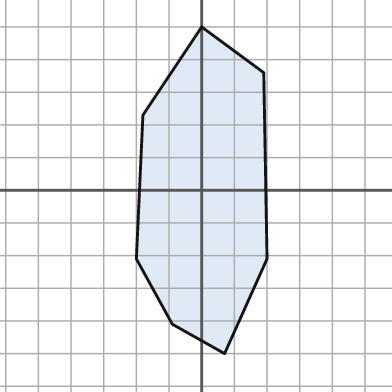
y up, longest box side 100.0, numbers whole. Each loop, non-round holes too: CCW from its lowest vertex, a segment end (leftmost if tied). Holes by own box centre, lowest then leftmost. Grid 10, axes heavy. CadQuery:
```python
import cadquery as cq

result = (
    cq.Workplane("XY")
    .moveTo(7.0, -50.0)
    .lineTo(20.0, -21.0)
    .lineTo(19.0, 36.0)
    .lineTo(0.0, 50.0)
    .lineTo(-18.0, 23.0)
    .lineTo(-20.0, -21.0)
    .lineTo(-9.0, -41.0)
    .close()
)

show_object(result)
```